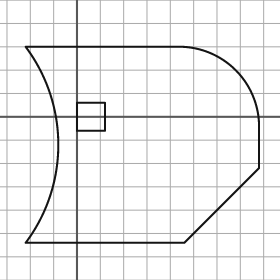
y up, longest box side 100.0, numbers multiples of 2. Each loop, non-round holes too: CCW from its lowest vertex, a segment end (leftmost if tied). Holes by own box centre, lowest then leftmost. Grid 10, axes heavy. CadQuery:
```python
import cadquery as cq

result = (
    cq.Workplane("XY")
    .moveTo(-22.0, -54.0)
    .lineTo(46.0, -54.0)
    .lineTo(78.0, -22.0)
    .lineTo(78.0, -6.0)
    .threePointArc((68.0, 20.0), (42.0, 30.0))
    .lineTo(-22.0, 30.0)
    .threePointArc((-8.0, -12.0), (-22.0, -54.0))
    .close()
    .moveTo(0.0, -6.0)
    .lineTo(12.0, -6.0)
    .lineTo(12.0, 6.0)
    .lineTo(0.0, 6.0)
    .close()
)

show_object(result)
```